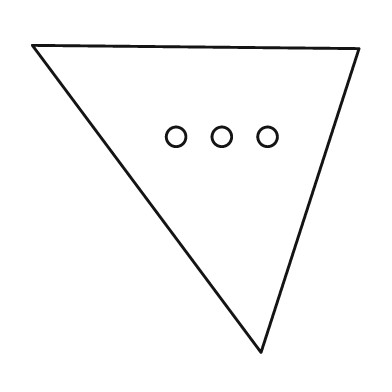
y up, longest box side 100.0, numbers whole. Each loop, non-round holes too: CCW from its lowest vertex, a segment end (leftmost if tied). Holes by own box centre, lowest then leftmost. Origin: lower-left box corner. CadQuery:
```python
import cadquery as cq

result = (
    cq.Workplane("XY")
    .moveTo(70.0, 0.0)
    .lineTo(100.0, 93.0)
    .lineTo(0.0, 94.0)
    .close()
    .moveTo(44.0, 66.0)
    .circle(3.0)
    .moveTo(58.0, 66.0)
    .circle(3.0)
    .moveTo(72.0, 66.0)
    .circle(3.0)
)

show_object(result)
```